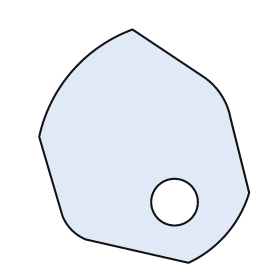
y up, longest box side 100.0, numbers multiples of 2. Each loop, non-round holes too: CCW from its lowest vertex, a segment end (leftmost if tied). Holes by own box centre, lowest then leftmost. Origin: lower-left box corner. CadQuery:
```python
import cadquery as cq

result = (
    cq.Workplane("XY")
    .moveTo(64.0, 0.0)
    .threePointArc((80.0, 12.0), (90.0, 30.0))
    .lineTo(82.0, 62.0)
    .threePointArc((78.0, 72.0), (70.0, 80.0))
    .lineTo(40.0, 100.0)
    .threePointArc((14.0, 82.0), (0.0, 54.0))
    .lineTo(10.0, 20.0)
    .threePointArc((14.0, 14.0), (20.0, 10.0))
    .close()
    .moveTo(58.0, 26.0)
    .circle(10.0)
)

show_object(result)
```